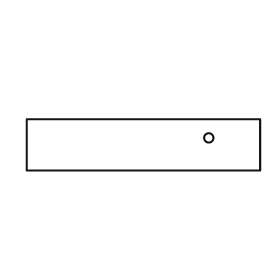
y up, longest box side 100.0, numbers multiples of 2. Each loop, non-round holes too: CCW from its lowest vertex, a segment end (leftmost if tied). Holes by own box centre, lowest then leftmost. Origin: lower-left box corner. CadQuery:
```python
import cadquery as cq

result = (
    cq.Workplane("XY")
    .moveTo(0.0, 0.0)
    .lineTo(100.0, 0.0)
    .lineTo(100.0, 22.0)
    .lineTo(0.0, 22.0)
    .close()
    .moveTo(78.0, 14.0)
    .circle(2.0)
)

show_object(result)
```